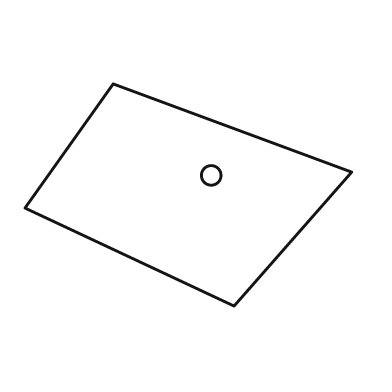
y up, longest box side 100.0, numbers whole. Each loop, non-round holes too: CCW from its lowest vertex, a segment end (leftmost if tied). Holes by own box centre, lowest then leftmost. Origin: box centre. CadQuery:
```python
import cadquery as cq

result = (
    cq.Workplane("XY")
    .moveTo(14.0, -34.0)
    .lineTo(50.0, 7.0)
    .lineTo(-23.0, 34.0)
    .lineTo(-50.0, -4.0)
    .close()
    .moveTo(7.0, 6.0)
    .circle(3.0)
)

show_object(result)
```